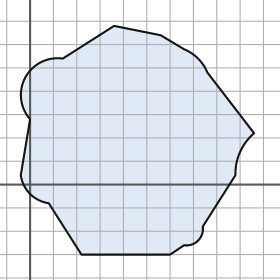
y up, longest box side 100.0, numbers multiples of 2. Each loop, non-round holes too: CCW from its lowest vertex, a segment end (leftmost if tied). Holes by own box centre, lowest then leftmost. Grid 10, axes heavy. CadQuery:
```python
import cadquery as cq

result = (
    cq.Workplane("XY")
    .moveTo(22.0, -30.0)
    .lineTo(60.0, -30.0)
    .lineTo(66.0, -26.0)
    .threePointArc((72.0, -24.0), (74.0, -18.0))
    .lineTo(88.0, 4.0)
    .threePointArc((90.0, 14.0), (96.0, 22.0))
    .lineTo(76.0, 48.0)
    .threePointArc((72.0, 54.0), (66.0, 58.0))
    .lineTo(56.0, 64.0)
    .lineTo(36.0, 68.0)
    .lineTo(14.0, 54.0)
    .threePointArc((-2.0, 46.0), (0.0, 28.0))
    .lineTo(-4.0, 4.0)
    .threePointArc((0.0, -4.0), (8.0, -8.0))
    .close()
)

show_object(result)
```